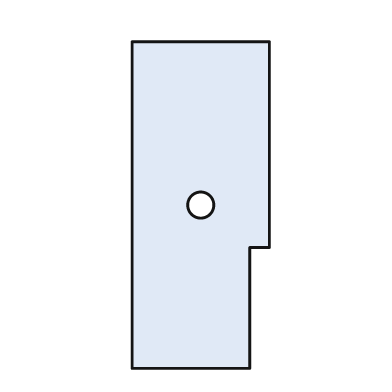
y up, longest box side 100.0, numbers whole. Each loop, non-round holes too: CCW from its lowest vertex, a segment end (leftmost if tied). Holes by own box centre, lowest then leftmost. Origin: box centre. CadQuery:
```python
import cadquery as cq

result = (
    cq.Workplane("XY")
    .moveTo(-21.0, -50.0)
    .lineTo(15.0, -50.0)
    .lineTo(15.0, -13.0)
    .lineTo(21.0, -13.0)
    .lineTo(21.0, 50.0)
    .lineTo(-21.0, 50.0)
    .close()
    .moveTo(0.0, 0.0)
    .circle(4.0)
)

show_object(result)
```